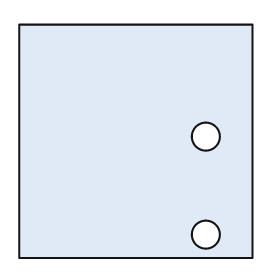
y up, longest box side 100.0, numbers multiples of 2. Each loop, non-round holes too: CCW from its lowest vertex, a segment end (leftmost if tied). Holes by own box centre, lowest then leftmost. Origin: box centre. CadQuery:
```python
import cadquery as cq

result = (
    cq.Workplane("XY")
    .moveTo(-50.0, -50.0)
    .lineTo(50.0, -50.0)
    .lineTo(50.0, 50.0)
    .lineTo(-50.0, 50.0)
    .close()
    .moveTo(30.0, -40.0)
    .circle(6.0)
    .moveTo(30.0, 2.0)
    .circle(6.0)
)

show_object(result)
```